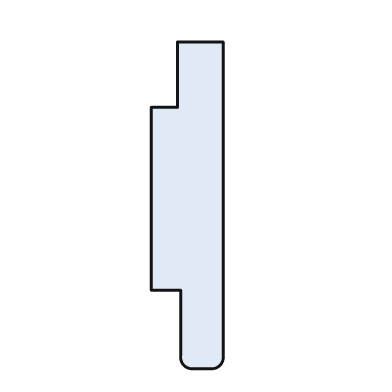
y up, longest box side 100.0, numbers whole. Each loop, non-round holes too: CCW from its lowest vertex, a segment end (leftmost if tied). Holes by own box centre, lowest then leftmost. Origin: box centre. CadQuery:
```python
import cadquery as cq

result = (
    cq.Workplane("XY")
    .moveTo(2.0, -50.0)
    .lineTo(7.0, -50.0)
    .threePointArc((10.0, -49.0), (11.0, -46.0))
    .lineTo(11.0, 50.0)
    .lineTo(-3.0, 50.0)
    .lineTo(-3.0, 30.0)
    .lineTo(-11.0, 30.0)
    .lineTo(-11.0, -26.0)
    .lineTo(-2.0, -26.0)
    .lineTo(-2.0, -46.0)
    .threePointArc((-1.0, -49.0), (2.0, -50.0))
    .close()
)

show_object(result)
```